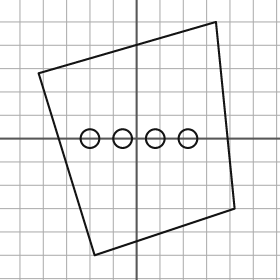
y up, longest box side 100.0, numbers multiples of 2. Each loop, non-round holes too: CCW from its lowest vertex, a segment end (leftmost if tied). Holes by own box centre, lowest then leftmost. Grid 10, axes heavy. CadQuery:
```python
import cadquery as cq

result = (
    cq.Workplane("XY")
    .moveTo(-18.0, -50.0)
    .lineTo(42.0, -30.0)
    .lineTo(34.0, 50.0)
    .lineTo(-42.0, 28.0)
    .close()
    .moveTo(-20.0, 0.0)
    .circle(4.0)
    .moveTo(-6.0, 0.0)
    .circle(4.0)
    .moveTo(8.0, 0.0)
    .circle(4.0)
    .moveTo(22.0, 0.0)
    .circle(4.0)
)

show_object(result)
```